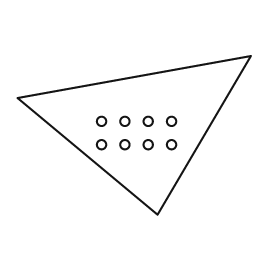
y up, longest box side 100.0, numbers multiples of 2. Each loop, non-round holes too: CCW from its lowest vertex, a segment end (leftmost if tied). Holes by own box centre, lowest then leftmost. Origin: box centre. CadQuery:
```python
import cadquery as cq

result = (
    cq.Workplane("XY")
    .moveTo(10.0, -34.0)
    .lineTo(50.0, 34.0)
    .lineTo(-50.0, 16.0)
    .close()
    .moveTo(-14.0, -4.0)
    .circle(2.0)
    .moveTo(-4.0, -4.0)
    .circle(2.0)
    .moveTo(6.0, -4.0)
    .circle(2.0)
    .moveTo(16.0, -4.0)
    .circle(2.0)
    .moveTo(-14.0, 6.0)
    .circle(2.0)
    .moveTo(-4.0, 6.0)
    .circle(2.0)
    .moveTo(6.0, 6.0)
    .circle(2.0)
    .moveTo(16.0, 6.0)
    .circle(2.0)
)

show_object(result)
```